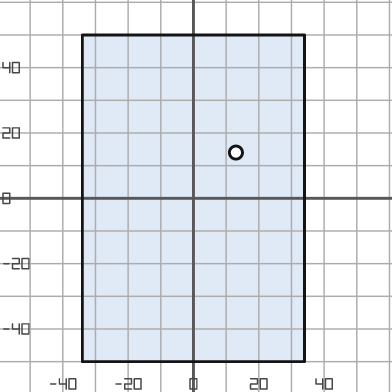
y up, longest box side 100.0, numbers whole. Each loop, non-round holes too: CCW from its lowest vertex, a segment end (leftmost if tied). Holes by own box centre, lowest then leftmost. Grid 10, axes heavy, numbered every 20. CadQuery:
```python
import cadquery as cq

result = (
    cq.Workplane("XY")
    .moveTo(-34.0, -50.0)
    .lineTo(34.0, -50.0)
    .lineTo(34.0, 50.0)
    .lineTo(-34.0, 50.0)
    .close()
    .moveTo(13.0, 14.0)
    .circle(2.0)
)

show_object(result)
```